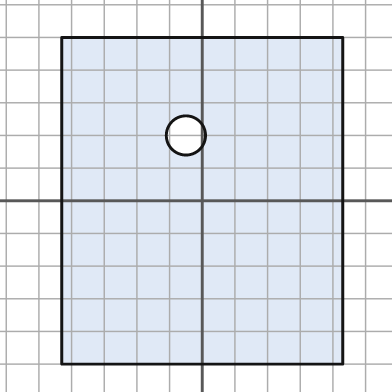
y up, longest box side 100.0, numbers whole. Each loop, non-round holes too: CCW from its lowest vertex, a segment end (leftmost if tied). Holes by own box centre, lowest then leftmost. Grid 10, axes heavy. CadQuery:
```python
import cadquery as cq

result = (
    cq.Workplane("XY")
    .moveTo(-43.0, -50.0)
    .lineTo(43.0, -50.0)
    .lineTo(43.0, 50.0)
    .lineTo(-43.0, 50.0)
    .close()
    .moveTo(-5.0, 20.0)
    .circle(6.0)
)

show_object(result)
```